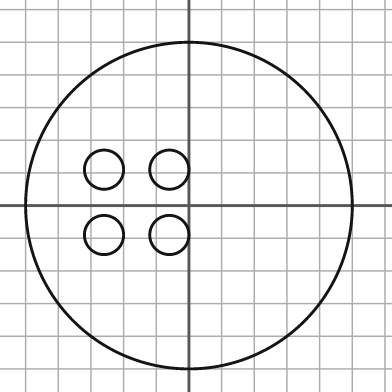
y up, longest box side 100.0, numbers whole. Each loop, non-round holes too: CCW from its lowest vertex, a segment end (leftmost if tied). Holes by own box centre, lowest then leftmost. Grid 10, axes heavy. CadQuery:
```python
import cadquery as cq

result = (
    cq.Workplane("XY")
    .moveTo(0.0, 0.0)
    .circle(50.0)
    .moveTo(-26.0, -9.0)
    .circle(6.0)
    .moveTo(-6.0, -9.0)
    .circle(6.0)
    .moveTo(-26.0, 11.0)
    .circle(6.0)
    .moveTo(-6.0, 11.0)
    .circle(6.0)
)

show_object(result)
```